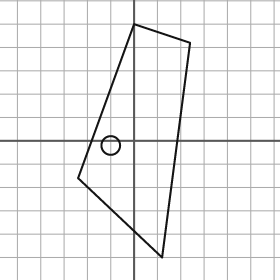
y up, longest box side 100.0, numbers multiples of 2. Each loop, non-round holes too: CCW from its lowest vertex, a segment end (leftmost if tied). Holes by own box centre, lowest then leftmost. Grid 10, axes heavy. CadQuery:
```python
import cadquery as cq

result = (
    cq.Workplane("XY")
    .moveTo(12.0, -50.0)
    .lineTo(24.0, 42.0)
    .lineTo(0.0, 50.0)
    .lineTo(-24.0, -16.0)
    .close()
    .moveTo(-10.0, -2.0)
    .circle(4.0)
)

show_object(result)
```